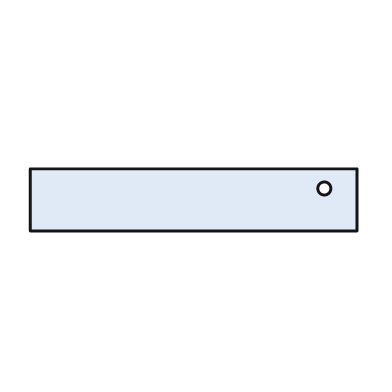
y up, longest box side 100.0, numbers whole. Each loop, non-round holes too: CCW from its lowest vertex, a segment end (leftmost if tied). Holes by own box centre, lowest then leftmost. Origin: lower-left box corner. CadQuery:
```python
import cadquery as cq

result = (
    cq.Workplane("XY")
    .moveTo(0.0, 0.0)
    .lineTo(100.0, 0.0)
    .lineTo(100.0, 19.0)
    .lineTo(0.0, 19.0)
    .close()
    .moveTo(90.0, 13.0)
    .circle(2.0)
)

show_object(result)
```